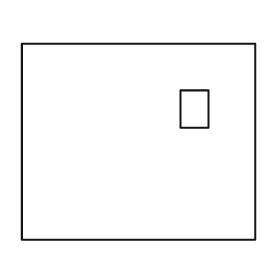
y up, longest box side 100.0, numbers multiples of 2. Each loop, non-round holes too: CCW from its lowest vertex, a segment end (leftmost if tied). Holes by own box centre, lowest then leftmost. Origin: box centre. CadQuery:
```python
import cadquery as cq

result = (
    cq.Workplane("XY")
    .moveTo(-50.0, -42.0)
    .lineTo(50.0, -42.0)
    .lineTo(50.0, 42.0)
    .lineTo(-50.0, 42.0)
    .close()
    .moveTo(18.0, 6.0)
    .lineTo(30.0, 6.0)
    .lineTo(30.0, 22.0)
    .lineTo(18.0, 22.0)
    .close()
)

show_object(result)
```